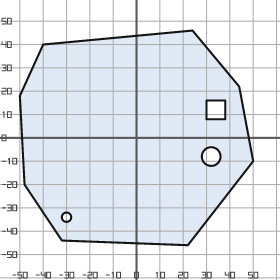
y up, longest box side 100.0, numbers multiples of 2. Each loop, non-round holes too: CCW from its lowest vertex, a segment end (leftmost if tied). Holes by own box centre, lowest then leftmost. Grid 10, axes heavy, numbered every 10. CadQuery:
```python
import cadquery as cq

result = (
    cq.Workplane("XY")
    .moveTo(22.0, -46.0)
    .lineTo(50.0, -10.0)
    .lineTo(44.0, 22.0)
    .lineTo(24.0, 46.0)
    .lineTo(-40.0, 40.0)
    .lineTo(-50.0, 18.0)
    .lineTo(-48.0, -20.0)
    .lineTo(-32.0, -44.0)
    .close()
    .moveTo(-30.0, -34.0)
    .circle(2.0)
    .moveTo(32.0, -8.0)
    .circle(4.0)
    .moveTo(30.0, 8.0)
    .lineTo(38.0, 8.0)
    .lineTo(38.0, 16.0)
    .lineTo(30.0, 16.0)
    .close()
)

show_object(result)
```